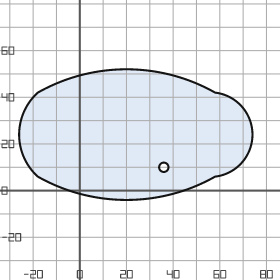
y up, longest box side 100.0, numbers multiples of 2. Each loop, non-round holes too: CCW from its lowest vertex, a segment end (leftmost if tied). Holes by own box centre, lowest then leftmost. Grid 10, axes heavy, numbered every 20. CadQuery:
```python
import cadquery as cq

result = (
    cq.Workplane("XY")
    .moveTo(-18.0, 6.0)
    .threePointArc((20.0, -4.0), (58.0, 6.0))
    .threePointArc((74.0, 24.0), (58.0, 42.0))
    .threePointArc((20.0, 52.0), (-18.0, 42.0))
    .threePointArc((-26.0, 24.0), (-18.0, 6.0))
    .close()
    .moveTo(36.0, 10.0)
    .circle(2.0)
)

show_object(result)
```